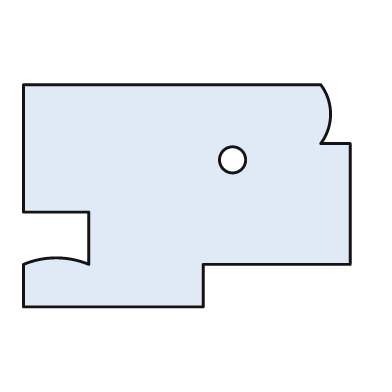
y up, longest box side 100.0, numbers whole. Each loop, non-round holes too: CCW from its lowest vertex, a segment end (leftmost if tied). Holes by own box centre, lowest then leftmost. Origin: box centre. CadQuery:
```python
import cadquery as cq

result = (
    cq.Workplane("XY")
    .moveTo(-50.0, -34.0)
    .lineTo(5.0, -34.0)
    .lineTo(5.0, -21.0)
    .lineTo(50.0, -21.0)
    .lineTo(50.0, 16.0)
    .lineTo(41.0, 16.0)
    .threePointArc((44.0, 25.0), (41.0, 34.0))
    .lineTo(-50.0, 34.0)
    .lineTo(-50.0, -5.0)
    .lineTo(-30.0, -5.0)
    .lineTo(-30.0, -21.0)
    .threePointArc((-40.0, -19.0), (-50.0, -21.0))
    .close()
    .moveTo(14.0, 11.0)
    .circle(4.0)
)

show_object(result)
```